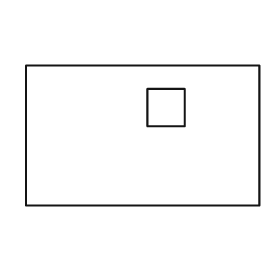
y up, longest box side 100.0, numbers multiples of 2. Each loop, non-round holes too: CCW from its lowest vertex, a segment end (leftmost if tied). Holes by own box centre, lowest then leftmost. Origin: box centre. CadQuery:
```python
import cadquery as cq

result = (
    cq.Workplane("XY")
    .moveTo(-50.0, -30.0)
    .lineTo(50.0, -30.0)
    .lineTo(50.0, 30.0)
    .lineTo(-50.0, 30.0)
    .close()
    .moveTo(2.0, 4.0)
    .lineTo(18.0, 4.0)
    .lineTo(18.0, 20.0)
    .lineTo(2.0, 20.0)
    .close()
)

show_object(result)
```